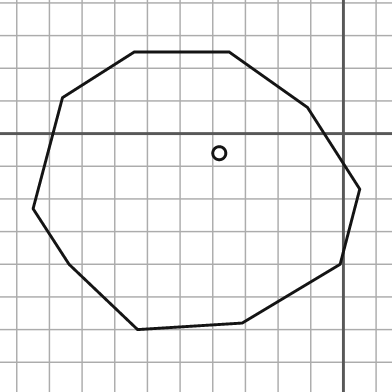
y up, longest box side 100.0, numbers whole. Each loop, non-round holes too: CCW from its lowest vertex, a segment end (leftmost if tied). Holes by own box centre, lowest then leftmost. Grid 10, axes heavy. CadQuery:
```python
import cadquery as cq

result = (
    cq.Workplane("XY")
    .moveTo(-63.0, -60.0)
    .lineTo(-31.0, -58.0)
    .lineTo(-1.0, -40.0)
    .lineTo(5.0, -17.0)
    .lineTo(-11.0, 8.0)
    .lineTo(-35.0, 25.0)
    .lineTo(-64.0, 25.0)
    .lineTo(-86.0, 11.0)
    .lineTo(-95.0, -23.0)
    .lineTo(-84.0, -40.0)
    .close()
    .moveTo(-38.0, -6.0)
    .circle(2.0)
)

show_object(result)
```